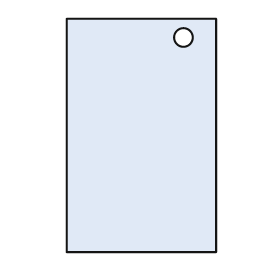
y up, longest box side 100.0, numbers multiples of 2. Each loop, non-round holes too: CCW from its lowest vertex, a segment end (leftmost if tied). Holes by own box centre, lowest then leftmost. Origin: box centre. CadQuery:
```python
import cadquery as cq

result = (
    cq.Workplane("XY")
    .moveTo(-32.0, -50.0)
    .lineTo(32.0, -50.0)
    .lineTo(32.0, 50.0)
    .lineTo(-32.0, 50.0)
    .close()
    .moveTo(18.0, 42.0)
    .circle(4.0)
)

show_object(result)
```